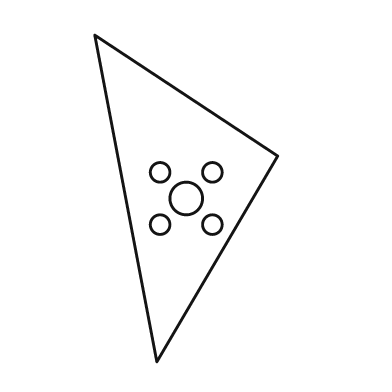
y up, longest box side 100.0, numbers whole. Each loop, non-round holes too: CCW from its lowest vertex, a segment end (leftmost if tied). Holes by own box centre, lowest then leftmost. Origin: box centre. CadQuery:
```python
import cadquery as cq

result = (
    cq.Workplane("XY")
    .moveTo(-9.0, -50.0)
    .lineTo(28.0, 13.0)
    .lineTo(-28.0, 50.0)
    .close()
    .moveTo(-8.0, -8.0)
    .circle(3.0)
    .moveTo(8.0, -8.0)
    .circle(3.0)
    .moveTo(0.0, 0.0)
    .circle(5.0)
    .moveTo(-8.0, 8.0)
    .circle(3.0)
    .moveTo(8.0, 8.0)
    .circle(3.0)
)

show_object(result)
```